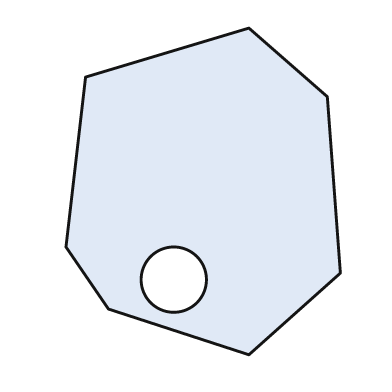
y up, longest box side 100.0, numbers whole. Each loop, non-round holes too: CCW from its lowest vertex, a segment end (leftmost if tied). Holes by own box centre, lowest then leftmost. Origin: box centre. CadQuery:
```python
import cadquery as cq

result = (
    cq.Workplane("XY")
    .moveTo(14.0, -50.0)
    .lineTo(42.0, -25.0)
    .lineTo(38.0, 29.0)
    .lineTo(14.0, 50.0)
    .lineTo(-36.0, 35.0)
    .lineTo(-42.0, -17.0)
    .lineTo(-29.0, -36.0)
    .close()
    .moveTo(-9.0, -27.0)
    .circle(10.0)
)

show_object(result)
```